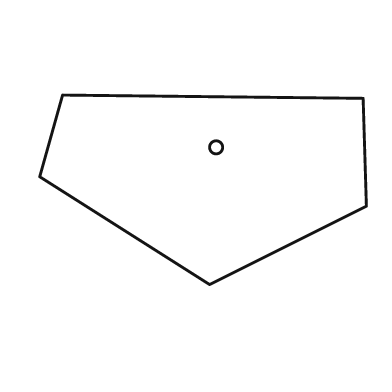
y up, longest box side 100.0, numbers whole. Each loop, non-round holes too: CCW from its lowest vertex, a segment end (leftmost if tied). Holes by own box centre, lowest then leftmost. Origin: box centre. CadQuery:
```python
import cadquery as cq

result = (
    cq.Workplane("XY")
    .moveTo(2.0, -29.0)
    .lineTo(50.0, -5.0)
    .lineTo(49.0, 28.0)
    .lineTo(-43.0, 29.0)
    .lineTo(-50.0, 4.0)
    .close()
    .moveTo(4.0, 13.0)
    .circle(2.0)
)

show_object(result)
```